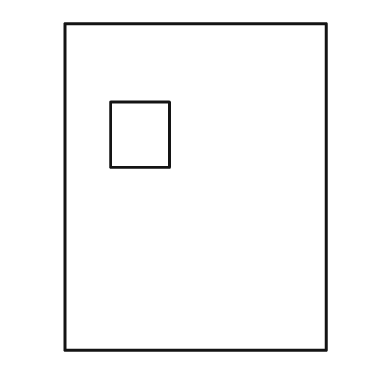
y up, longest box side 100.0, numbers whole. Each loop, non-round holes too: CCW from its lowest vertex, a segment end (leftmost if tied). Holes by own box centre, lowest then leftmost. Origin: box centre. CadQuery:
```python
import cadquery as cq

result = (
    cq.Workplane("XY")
    .moveTo(-40.0, -50.0)
    .lineTo(40.0, -50.0)
    .lineTo(40.0, 50.0)
    .lineTo(-40.0, 50.0)
    .close()
    .moveTo(-26.0, 6.0)
    .lineTo(-8.0, 6.0)
    .lineTo(-8.0, 26.0)
    .lineTo(-26.0, 26.0)
    .close()
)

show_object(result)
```